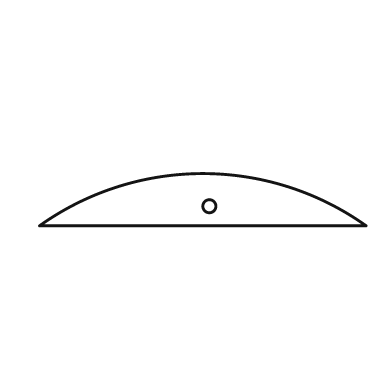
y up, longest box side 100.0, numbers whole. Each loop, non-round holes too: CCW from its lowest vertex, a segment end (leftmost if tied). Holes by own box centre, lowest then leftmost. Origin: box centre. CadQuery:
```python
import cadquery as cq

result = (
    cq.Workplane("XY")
    .moveTo(-50.0, -8.0)
    .lineTo(50.0, -8.0)
    .threePointArc((0.0, 8.0), (-50.0, -8.0))
    .close()
    .moveTo(2.0, -2.0)
    .circle(2.0)
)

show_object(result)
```